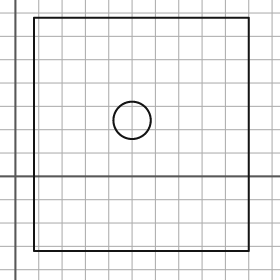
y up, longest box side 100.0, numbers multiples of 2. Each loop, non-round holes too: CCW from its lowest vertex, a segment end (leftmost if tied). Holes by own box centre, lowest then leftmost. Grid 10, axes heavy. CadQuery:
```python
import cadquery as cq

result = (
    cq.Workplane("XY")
    .moveTo(8.0, -32.0)
    .lineTo(100.0, -32.0)
    .lineTo(100.0, 68.0)
    .lineTo(8.0, 68.0)
    .close()
    .moveTo(50.0, 24.0)
    .circle(8.0)
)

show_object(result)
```